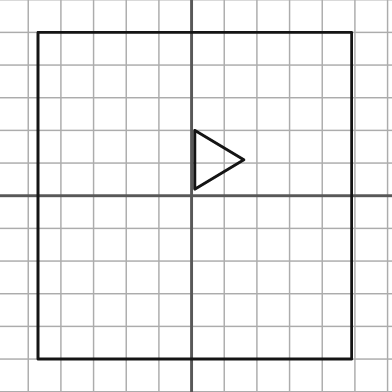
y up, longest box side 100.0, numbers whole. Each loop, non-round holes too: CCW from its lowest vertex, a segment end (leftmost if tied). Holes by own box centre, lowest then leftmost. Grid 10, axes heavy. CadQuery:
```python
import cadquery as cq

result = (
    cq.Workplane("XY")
    .moveTo(-47.0, -50.0)
    .lineTo(49.0, -50.0)
    .lineTo(49.0, 50.0)
    .lineTo(-47.0, 50.0)
    .close()
    .moveTo(1.0, 2.0)
    .lineTo(16.0, 11.0)
    .lineTo(1.0, 20.0)
    .close()
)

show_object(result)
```